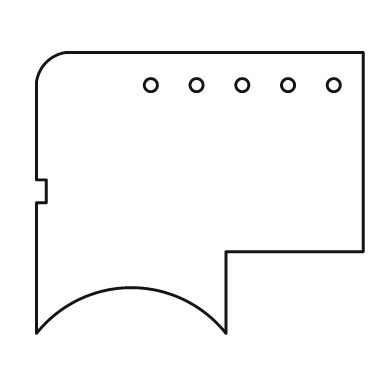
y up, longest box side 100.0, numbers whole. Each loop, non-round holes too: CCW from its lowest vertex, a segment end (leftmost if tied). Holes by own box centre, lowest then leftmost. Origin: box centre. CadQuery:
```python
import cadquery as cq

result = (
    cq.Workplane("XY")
    .moveTo(-50.0, -43.0)
    .threePointArc((-21.0, -29.0), (8.0, -43.0))
    .lineTo(8.0, -18.0)
    .lineTo(50.0, -18.0)
    .lineTo(50.0, 43.0)
    .lineTo(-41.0, 43.0)
    .threePointArc((-47.0, 40.0), (-50.0, 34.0))
    .lineTo(-50.0, 4.0)
    .lineTo(-47.0, 4.0)
    .lineTo(-47.0, -3.0)
    .lineTo(-50.0, -3.0)
    .close()
    .moveTo(-15.0, 33.0)
    .circle(2.0)
    .moveTo(-1.0, 33.0)
    .circle(2.0)
    .moveTo(13.0, 33.0)
    .circle(2.0)
    .moveTo(27.0, 33.0)
    .circle(2.0)
    .moveTo(41.0, 33.0)
    .circle(2.0)
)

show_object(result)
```